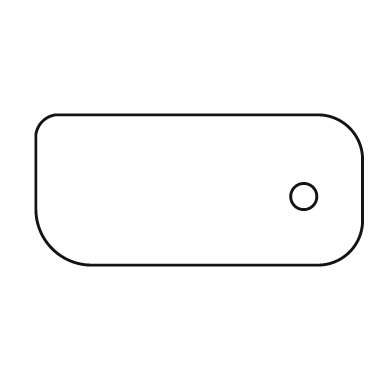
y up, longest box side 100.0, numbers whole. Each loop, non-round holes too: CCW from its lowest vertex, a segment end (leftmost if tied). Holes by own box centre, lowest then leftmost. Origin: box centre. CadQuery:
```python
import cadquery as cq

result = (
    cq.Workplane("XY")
    .moveTo(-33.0, -23.0)
    .lineTo(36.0, -23.0)
    .threePointArc((46.0, -19.0), (50.0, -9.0))
    .lineTo(50.0, 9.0)
    .threePointArc((46.0, 19.0), (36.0, 23.0))
    .lineTo(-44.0, 23.0)
    .threePointArc((-48.0, 21.0), (-50.0, 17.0))
    .lineTo(-50.0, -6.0)
    .threePointArc((-45.0, -18.0), (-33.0, -23.0))
    .close()
    .moveTo(32.0, -2.0)
    .circle(4.0)
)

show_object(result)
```